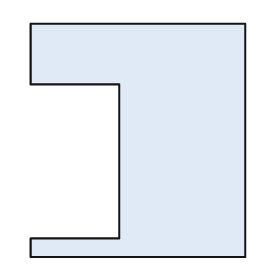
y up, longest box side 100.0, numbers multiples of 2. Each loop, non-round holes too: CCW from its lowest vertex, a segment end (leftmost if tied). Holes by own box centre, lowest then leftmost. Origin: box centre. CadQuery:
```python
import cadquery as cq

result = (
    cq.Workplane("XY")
    .moveTo(-46.0, -50.0)
    .lineTo(46.0, -50.0)
    .lineTo(46.0, 50.0)
    .lineTo(-46.0, 50.0)
    .lineTo(-46.0, 24.0)
    .lineTo(-8.0, 24.0)
    .lineTo(-8.0, -42.0)
    .lineTo(-46.0, -42.0)
    .close()
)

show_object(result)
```